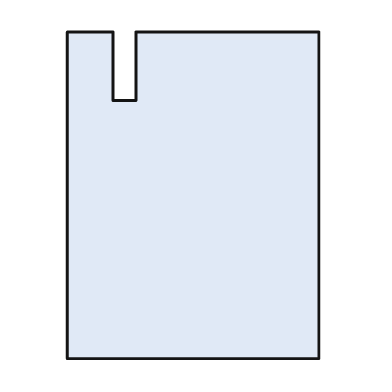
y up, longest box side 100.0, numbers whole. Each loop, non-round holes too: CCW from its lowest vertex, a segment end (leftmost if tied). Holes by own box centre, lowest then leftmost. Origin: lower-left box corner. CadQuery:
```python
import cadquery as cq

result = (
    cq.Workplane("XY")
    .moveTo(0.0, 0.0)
    .lineTo(77.0, 0.0)
    .lineTo(77.0, 100.0)
    .lineTo(21.0, 100.0)
    .lineTo(21.0, 79.0)
    .lineTo(14.0, 79.0)
    .lineTo(14.0, 100.0)
    .lineTo(0.0, 100.0)
    .close()
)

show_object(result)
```